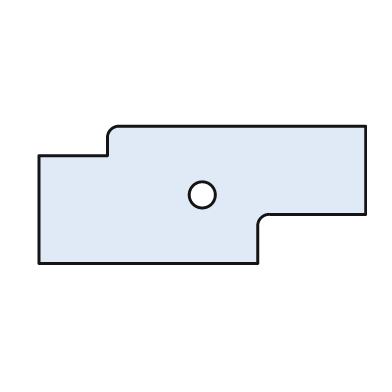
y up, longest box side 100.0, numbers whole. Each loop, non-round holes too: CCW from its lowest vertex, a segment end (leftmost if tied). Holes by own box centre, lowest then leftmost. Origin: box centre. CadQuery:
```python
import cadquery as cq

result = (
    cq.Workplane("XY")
    .moveTo(-50.0, -21.0)
    .lineTo(17.0, -21.0)
    .lineTo(17.0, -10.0)
    .threePointArc((18.0, -7.0), (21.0, -6.0))
    .lineTo(50.0, -6.0)
    .lineTo(50.0, 21.0)
    .lineTo(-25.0, 21.0)
    .threePointArc((-28.0, 20.0), (-29.0, 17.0))
    .lineTo(-29.0, 12.0)
    .lineTo(-50.0, 12.0)
    .close()
    .moveTo(0.0, 0.0)
    .circle(4.0)
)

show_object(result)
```